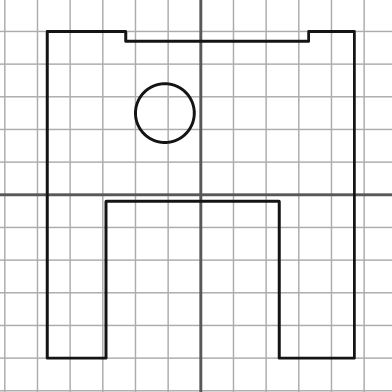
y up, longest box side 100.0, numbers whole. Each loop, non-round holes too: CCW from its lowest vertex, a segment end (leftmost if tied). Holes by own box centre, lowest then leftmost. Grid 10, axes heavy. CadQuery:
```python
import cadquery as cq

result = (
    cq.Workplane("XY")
    .moveTo(-47.0, -50.0)
    .lineTo(-29.0, -50.0)
    .lineTo(-29.0, -2.0)
    .lineTo(24.0, -2.0)
    .lineTo(24.0, -50.0)
    .lineTo(47.0, -50.0)
    .lineTo(47.0, 50.0)
    .lineTo(33.0, 50.0)
    .lineTo(33.0, 47.0)
    .lineTo(-23.0, 47.0)
    .lineTo(-23.0, 50.0)
    .lineTo(-47.0, 50.0)
    .close()
    .moveTo(-11.0, 25.0)
    .circle(9.0)
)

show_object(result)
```